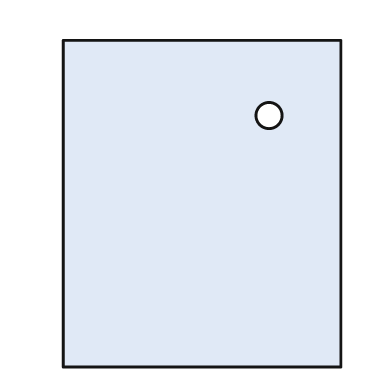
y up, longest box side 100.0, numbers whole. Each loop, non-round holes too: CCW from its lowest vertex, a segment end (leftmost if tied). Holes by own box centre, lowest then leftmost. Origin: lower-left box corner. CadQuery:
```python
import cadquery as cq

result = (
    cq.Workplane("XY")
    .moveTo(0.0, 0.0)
    .lineTo(85.0, 0.0)
    .lineTo(85.0, 100.0)
    .lineTo(0.0, 100.0)
    .close()
    .moveTo(63.0, 77.0)
    .circle(4.0)
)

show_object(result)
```